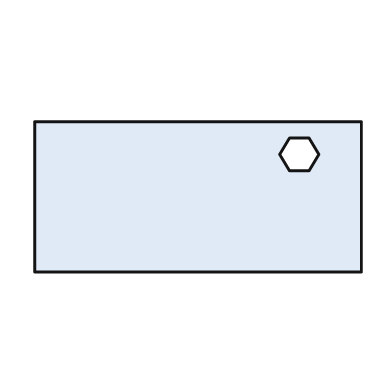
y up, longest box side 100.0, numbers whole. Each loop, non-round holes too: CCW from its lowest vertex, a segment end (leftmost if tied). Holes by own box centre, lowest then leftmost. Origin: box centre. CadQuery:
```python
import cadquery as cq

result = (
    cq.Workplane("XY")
    .moveTo(-50.0, -23.0)
    .lineTo(50.0, -23.0)
    .lineTo(50.0, 23.0)
    .lineTo(-50.0, 23.0)
    .close()
    .moveTo(28.0, 8.0)
    .lineTo(34.0, 8.0)
    .lineTo(37.0, 13.0)
    .lineTo(34.0, 18.0)
    .lineTo(28.0, 18.0)
    .lineTo(25.0, 13.0)
    .close()
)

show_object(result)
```